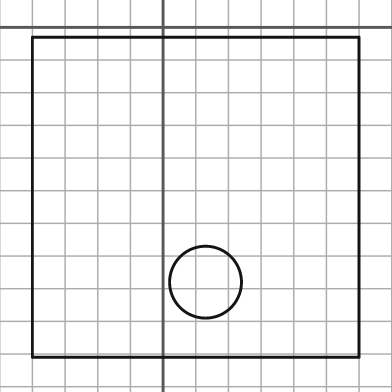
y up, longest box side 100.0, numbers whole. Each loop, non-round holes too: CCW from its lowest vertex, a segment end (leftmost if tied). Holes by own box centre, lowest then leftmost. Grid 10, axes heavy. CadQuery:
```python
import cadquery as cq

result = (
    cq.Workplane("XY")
    .moveTo(-40.0, -101.0)
    .lineTo(60.0, -101.0)
    .lineTo(60.0, -3.0)
    .lineTo(-40.0, -3.0)
    .close()
    .moveTo(13.0, -78.0)
    .circle(11.0)
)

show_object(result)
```